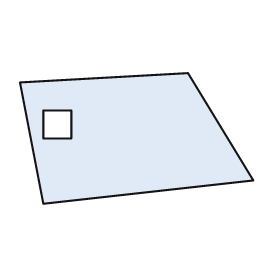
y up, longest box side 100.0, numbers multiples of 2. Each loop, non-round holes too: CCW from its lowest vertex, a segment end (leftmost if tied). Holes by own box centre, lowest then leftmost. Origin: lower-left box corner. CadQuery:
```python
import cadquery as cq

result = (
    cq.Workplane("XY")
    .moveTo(10.0, 0.0)
    .lineTo(100.0, 10.0)
    .lineTo(72.0, 56.0)
    .lineTo(0.0, 52.0)
    .close()
    .moveTo(10.0, 28.0)
    .lineTo(22.0, 28.0)
    .lineTo(22.0, 40.0)
    .lineTo(10.0, 40.0)
    .close()
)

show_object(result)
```